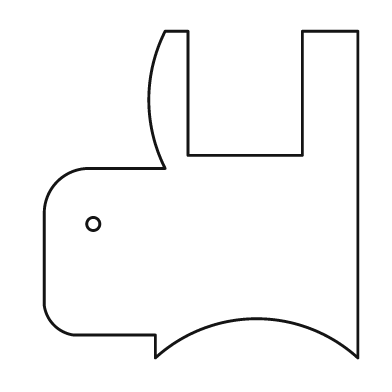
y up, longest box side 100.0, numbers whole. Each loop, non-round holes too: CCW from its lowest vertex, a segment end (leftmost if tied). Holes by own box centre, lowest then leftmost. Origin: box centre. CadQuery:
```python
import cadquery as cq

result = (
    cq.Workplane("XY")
    .moveTo(-14.0, -50.0)
    .threePointArc((17.0, -38.0), (48.0, -50.0))
    .lineTo(48.0, 50.0)
    .lineTo(31.0, 50.0)
    .lineTo(31.0, 12.0)
    .lineTo(-4.0, 12.0)
    .lineTo(-4.0, 50.0)
    .lineTo(-11.0, 50.0)
    .threePointArc((-16.0, 29.0), (-11.0, 8.0))
    .lineTo(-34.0, 8.0)
    .threePointArc((-44.0, 4.0), (-48.0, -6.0))
    .lineTo(-48.0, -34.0)
    .threePointArc((-45.0, -40.0), (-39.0, -43.0))
    .lineTo(-14.0, -43.0)
    .close()
    .moveTo(-33.0, -9.0)
    .circle(2.0)
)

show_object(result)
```